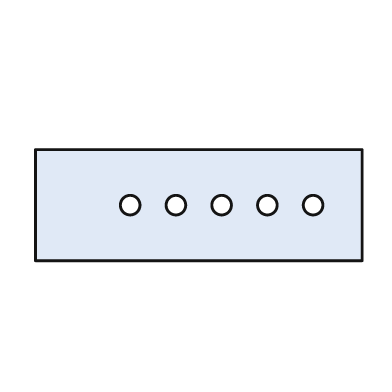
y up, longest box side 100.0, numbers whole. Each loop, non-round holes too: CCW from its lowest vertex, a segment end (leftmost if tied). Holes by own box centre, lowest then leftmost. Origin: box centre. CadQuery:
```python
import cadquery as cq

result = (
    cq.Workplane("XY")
    .moveTo(-50.0, -17.0)
    .lineTo(50.0, -17.0)
    .lineTo(50.0, 17.0)
    .lineTo(-50.0, 17.0)
    .close()
    .moveTo(-21.0, 0.0)
    .circle(3.0)
    .moveTo(-7.0, 0.0)
    .circle(3.0)
    .moveTo(7.0, 0.0)
    .circle(3.0)
    .moveTo(21.0, 0.0)
    .circle(3.0)
    .moveTo(35.0, 0.0)
    .circle(3.0)
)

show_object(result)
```